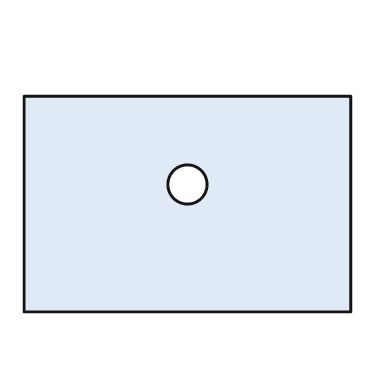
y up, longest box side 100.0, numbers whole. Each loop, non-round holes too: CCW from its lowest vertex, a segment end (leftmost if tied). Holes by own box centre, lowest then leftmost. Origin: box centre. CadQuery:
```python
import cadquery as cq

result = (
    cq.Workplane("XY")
    .moveTo(-50.0, -33.0)
    .lineTo(50.0, -33.0)
    .lineTo(50.0, 33.0)
    .lineTo(-50.0, 33.0)
    .close()
    .moveTo(0.0, 6.0)
    .circle(6.0)
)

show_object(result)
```